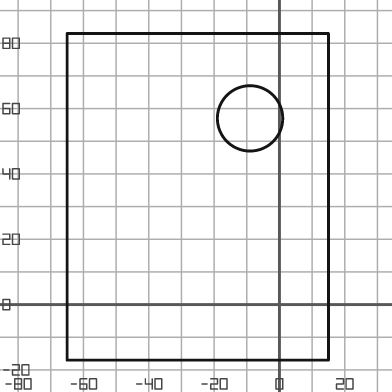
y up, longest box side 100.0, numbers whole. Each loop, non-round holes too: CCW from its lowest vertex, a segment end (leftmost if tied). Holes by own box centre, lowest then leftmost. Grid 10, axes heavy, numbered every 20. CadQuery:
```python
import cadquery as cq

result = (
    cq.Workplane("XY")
    .moveTo(-65.0, -17.0)
    .lineTo(15.0, -17.0)
    .lineTo(15.0, 83.0)
    .lineTo(-65.0, 83.0)
    .close()
    .moveTo(-9.0, 57.0)
    .circle(10.0)
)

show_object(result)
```